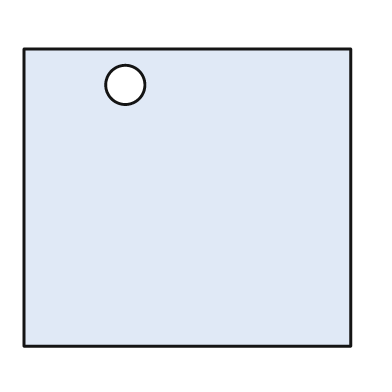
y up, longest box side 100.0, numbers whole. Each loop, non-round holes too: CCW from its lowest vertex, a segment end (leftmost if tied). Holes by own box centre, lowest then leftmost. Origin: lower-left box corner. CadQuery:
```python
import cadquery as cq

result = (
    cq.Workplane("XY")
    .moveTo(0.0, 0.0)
    .lineTo(100.0, 0.0)
    .lineTo(100.0, 91.0)
    .lineTo(0.0, 91.0)
    .close()
    .moveTo(31.0, 80.0)
    .circle(6.0)
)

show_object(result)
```